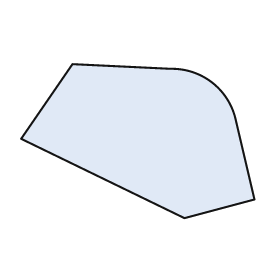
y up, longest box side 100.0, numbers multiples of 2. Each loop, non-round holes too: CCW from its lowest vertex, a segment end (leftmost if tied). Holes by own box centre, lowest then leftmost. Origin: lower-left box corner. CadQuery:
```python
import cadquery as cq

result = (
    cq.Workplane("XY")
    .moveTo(70.0, 0.0)
    .lineTo(100.0, 8.0)
    .lineTo(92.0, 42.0)
    .threePointArc((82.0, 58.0), (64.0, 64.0))
    .lineTo(22.0, 66.0)
    .lineTo(0.0, 34.0)
    .close()
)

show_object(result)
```